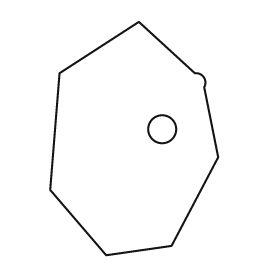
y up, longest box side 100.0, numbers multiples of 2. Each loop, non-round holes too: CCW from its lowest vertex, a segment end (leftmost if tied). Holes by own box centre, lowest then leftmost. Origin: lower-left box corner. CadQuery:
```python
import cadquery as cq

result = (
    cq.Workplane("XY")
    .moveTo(24.0, 0.0)
    .lineTo(52.0, 4.0)
    .lineTo(72.0, 42.0)
    .lineTo(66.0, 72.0)
    .threePointArc((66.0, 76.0), (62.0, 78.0))
    .lineTo(38.0, 100.0)
    .lineTo(4.0, 78.0)
    .lineTo(0.0, 28.0)
    .close()
    .moveTo(48.0, 54.0)
    .circle(6.0)
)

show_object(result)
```